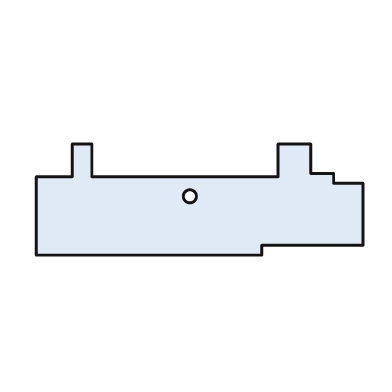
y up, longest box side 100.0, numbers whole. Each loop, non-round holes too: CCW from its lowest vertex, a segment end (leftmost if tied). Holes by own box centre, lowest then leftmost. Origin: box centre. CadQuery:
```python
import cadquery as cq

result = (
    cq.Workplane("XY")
    .moveTo(-50.0, -17.0)
    .lineTo(19.0, -17.0)
    .lineTo(19.0, -14.0)
    .lineTo(50.0, -14.0)
    .lineTo(50.0, 5.0)
    .lineTo(41.0, 5.0)
    .lineTo(41.0, 8.0)
    .lineTo(34.0, 8.0)
    .lineTo(34.0, 17.0)
    .lineTo(24.0, 17.0)
    .lineTo(24.0, 7.0)
    .lineTo(-33.0, 7.0)
    .lineTo(-33.0, 17.0)
    .lineTo(-39.0, 17.0)
    .lineTo(-39.0, 7.0)
    .lineTo(-50.0, 7.0)
    .close()
    .moveTo(-3.0, 1.0)
    .circle(2.0)
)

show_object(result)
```